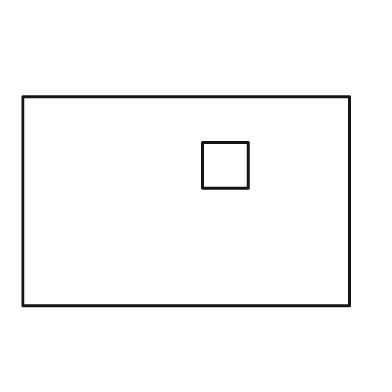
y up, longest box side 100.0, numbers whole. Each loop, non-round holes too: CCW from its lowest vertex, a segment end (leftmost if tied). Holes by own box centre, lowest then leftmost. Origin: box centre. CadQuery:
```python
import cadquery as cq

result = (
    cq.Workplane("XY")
    .moveTo(-50.0, -32.0)
    .lineTo(50.0, -32.0)
    .lineTo(50.0, 32.0)
    .lineTo(-50.0, 32.0)
    .close()
    .moveTo(5.0, 4.0)
    .lineTo(19.0, 4.0)
    .lineTo(19.0, 18.0)
    .lineTo(5.0, 18.0)
    .close()
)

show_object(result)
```